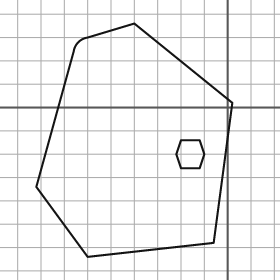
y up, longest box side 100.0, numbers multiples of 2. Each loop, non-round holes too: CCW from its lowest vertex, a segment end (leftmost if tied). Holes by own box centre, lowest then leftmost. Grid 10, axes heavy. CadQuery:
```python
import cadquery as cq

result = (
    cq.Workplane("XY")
    .moveTo(-60.0, -64.0)
    .lineTo(-6.0, -58.0)
    .lineTo(2.0, 2.0)
    .lineTo(-40.0, 36.0)
    .lineTo(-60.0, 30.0)
    .threePointArc((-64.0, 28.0), (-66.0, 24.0))
    .lineTo(-82.0, -34.0)
    .close()
    .moveTo(-20.0, -26.0)
    .lineTo(-12.0, -26.0)
    .lineTo(-10.0, -20.0)
    .lineTo(-12.0, -14.0)
    .lineTo(-20.0, -14.0)
    .lineTo(-22.0, -20.0)
    .close()
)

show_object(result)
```